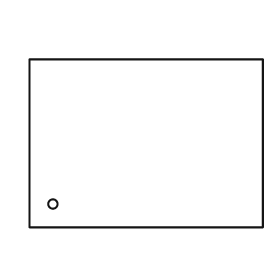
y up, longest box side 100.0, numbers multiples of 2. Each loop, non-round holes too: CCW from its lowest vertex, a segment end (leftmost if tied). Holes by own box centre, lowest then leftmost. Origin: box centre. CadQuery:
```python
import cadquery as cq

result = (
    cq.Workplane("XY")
    .moveTo(-50.0, -36.0)
    .lineTo(50.0, -36.0)
    .lineTo(50.0, 36.0)
    .lineTo(-50.0, 36.0)
    .close()
    .moveTo(-40.0, -26.0)
    .circle(2.0)
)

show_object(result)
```